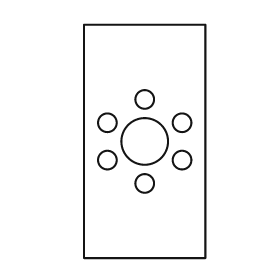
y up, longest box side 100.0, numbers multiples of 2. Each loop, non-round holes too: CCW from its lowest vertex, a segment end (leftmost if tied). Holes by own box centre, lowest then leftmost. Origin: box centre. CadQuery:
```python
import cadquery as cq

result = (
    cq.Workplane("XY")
    .moveTo(-26.0, -50.0)
    .lineTo(26.0, -50.0)
    .lineTo(26.0, 50.0)
    .lineTo(-26.0, 50.0)
    .close()
    .moveTo(0.0, -18.0)
    .circle(4.0)
    .moveTo(-16.0, -8.0)
    .circle(4.0)
    .moveTo(16.0, -8.0)
    .circle(4.0)
    .moveTo(0.0, 0.0)
    .circle(10.0)
    .moveTo(-16.0, 8.0)
    .circle(4.0)
    .moveTo(16.0, 8.0)
    .circle(4.0)
    .moveTo(0.0, 18.0)
    .circle(4.0)
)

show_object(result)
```